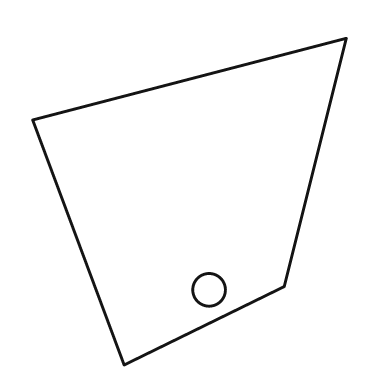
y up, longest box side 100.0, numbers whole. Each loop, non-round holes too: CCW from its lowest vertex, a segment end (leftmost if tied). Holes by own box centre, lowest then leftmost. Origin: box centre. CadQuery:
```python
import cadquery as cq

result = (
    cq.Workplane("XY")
    .moveTo(-20.0, -50.0)
    .lineTo(29.0, -26.0)
    .lineTo(48.0, 50.0)
    .lineTo(-48.0, 25.0)
    .close()
    .moveTo(6.0, -27.0)
    .circle(5.0)
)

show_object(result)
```